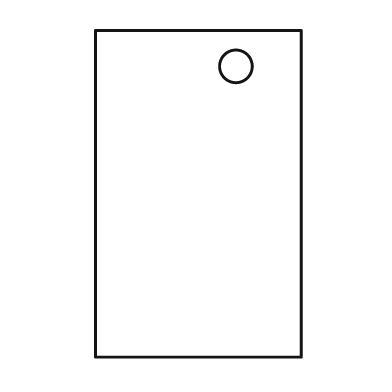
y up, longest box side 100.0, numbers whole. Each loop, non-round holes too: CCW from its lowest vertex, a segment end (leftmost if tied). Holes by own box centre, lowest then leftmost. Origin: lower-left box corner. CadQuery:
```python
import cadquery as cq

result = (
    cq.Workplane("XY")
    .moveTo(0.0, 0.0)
    .lineTo(63.0, 0.0)
    .lineTo(63.0, 100.0)
    .lineTo(0.0, 100.0)
    .close()
    .moveTo(43.0, 89.0)
    .circle(5.0)
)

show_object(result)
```